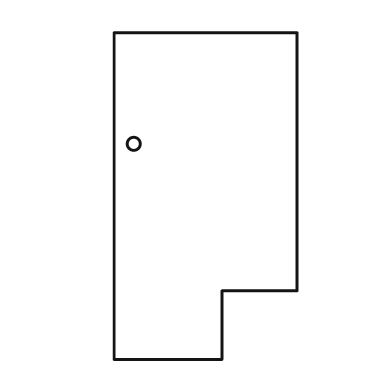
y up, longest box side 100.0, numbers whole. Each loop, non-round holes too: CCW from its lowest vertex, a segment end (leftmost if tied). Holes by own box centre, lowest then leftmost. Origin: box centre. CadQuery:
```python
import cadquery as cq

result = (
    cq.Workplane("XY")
    .moveTo(-28.0, -50.0)
    .lineTo(5.0, -50.0)
    .lineTo(5.0, -29.0)
    .lineTo(28.0, -29.0)
    .lineTo(28.0, 50.0)
    .lineTo(-28.0, 50.0)
    .close()
    .moveTo(-22.0, 16.0)
    .circle(2.0)
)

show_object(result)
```